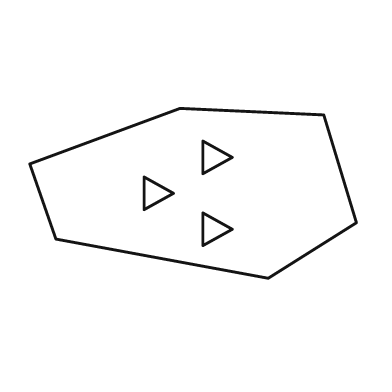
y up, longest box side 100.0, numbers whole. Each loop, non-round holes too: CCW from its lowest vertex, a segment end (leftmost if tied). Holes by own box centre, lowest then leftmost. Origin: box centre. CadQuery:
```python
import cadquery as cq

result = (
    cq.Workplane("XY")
    .moveTo(23.0, -26.0)
    .lineTo(50.0, -9.0)
    .lineTo(40.0, 24.0)
    .lineTo(-4.0, 26.0)
    .lineTo(-50.0, 9.0)
    .lineTo(-42.0, -14.0)
    .close()
    .moveTo(3.0, -16.0)
    .lineTo(12.0, -11.0)
    .lineTo(3.0, -6.0)
    .close()
    .moveTo(-15.0, -5.0)
    .lineTo(-6.0, 0.0)
    .lineTo(-15.0, 5.0)
    .close()
    .moveTo(3.0, 6.0)
    .lineTo(12.0, 11.0)
    .lineTo(3.0, 16.0)
    .close()
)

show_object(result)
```